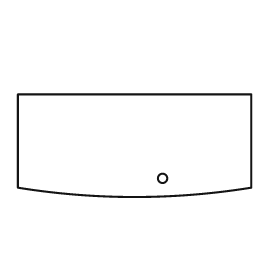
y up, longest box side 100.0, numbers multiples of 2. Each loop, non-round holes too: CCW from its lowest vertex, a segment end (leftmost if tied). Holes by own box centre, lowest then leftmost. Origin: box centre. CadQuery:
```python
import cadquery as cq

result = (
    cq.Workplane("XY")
    .moveTo(-50.0, -18.0)
    .threePointArc((0.0, -22.0), (50.0, -18.0))
    .lineTo(50.0, 22.0)
    .lineTo(-50.0, 22.0)
    .close()
    .moveTo(12.0, -14.0)
    .circle(2.0)
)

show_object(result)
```